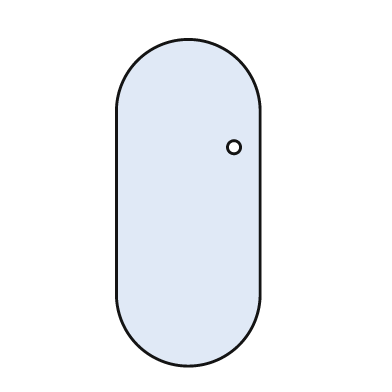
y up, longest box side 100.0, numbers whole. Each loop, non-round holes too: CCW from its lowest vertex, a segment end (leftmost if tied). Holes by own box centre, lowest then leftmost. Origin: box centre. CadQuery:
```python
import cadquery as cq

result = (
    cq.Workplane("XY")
    .moveTo(-22.0, -28.0)
    .threePointArc((0.0, -50.0), (22.0, -28.0))
    .lineTo(22.0, 28.0)
    .threePointArc((0.0, 50.0), (-22.0, 28.0))
    .close()
    .moveTo(14.0, 17.0)
    .circle(2.0)
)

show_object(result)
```